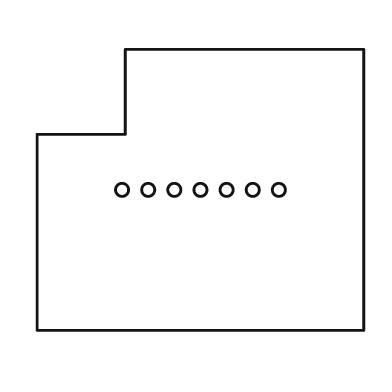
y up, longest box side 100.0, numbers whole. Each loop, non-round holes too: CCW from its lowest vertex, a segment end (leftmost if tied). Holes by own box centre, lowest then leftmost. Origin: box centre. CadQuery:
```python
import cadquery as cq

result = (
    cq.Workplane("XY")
    .moveTo(-50.0, -43.0)
    .lineTo(50.0, -43.0)
    .lineTo(50.0, 43.0)
    .lineTo(-23.0, 43.0)
    .lineTo(-23.0, 17.0)
    .lineTo(-50.0, 17.0)
    .close()
    .moveTo(-24.0, 0.0)
    .circle(2.0)
    .moveTo(-16.0, 0.0)
    .circle(2.0)
    .moveTo(-8.0, 0.0)
    .circle(2.0)
    .moveTo(0.0, 0.0)
    .circle(2.0)
    .moveTo(8.0, 0.0)
    .circle(2.0)
    .moveTo(16.0, 0.0)
    .circle(2.0)
    .moveTo(24.0, 0.0)
    .circle(2.0)
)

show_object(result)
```